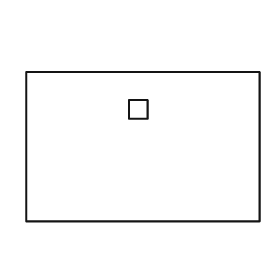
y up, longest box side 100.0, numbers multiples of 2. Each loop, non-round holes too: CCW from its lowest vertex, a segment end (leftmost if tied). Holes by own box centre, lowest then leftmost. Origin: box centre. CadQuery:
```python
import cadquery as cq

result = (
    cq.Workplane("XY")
    .moveTo(-50.0, -32.0)
    .lineTo(50.0, -32.0)
    .lineTo(50.0, 32.0)
    .lineTo(-50.0, 32.0)
    .close()
    .moveTo(-6.0, 12.0)
    .lineTo(2.0, 12.0)
    .lineTo(2.0, 20.0)
    .lineTo(-6.0, 20.0)
    .close()
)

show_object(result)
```